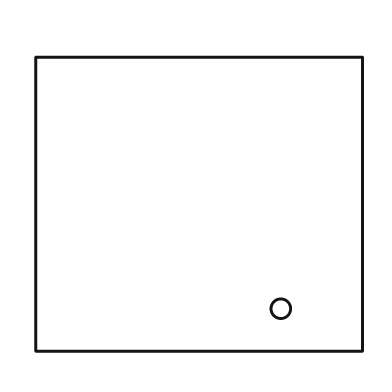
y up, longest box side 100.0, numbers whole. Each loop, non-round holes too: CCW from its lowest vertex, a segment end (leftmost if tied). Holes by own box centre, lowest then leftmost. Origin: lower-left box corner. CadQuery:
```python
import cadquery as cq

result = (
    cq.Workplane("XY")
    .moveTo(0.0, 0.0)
    .lineTo(100.0, 0.0)
    .lineTo(100.0, 90.0)
    .lineTo(0.0, 90.0)
    .close()
    .moveTo(75.0, 13.0)
    .circle(3.0)
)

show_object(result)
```